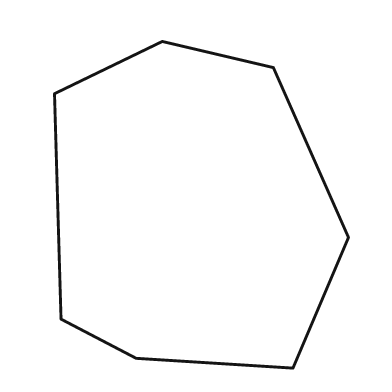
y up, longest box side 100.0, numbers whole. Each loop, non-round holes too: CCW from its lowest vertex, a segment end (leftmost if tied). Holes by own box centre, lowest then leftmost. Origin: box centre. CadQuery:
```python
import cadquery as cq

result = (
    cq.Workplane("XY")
    .moveTo(28.0, -50.0)
    .lineTo(45.0, -10.0)
    .lineTo(22.0, 42.0)
    .lineTo(-12.0, 50.0)
    .lineTo(-45.0, 34.0)
    .lineTo(-43.0, -35.0)
    .lineTo(-20.0, -47.0)
    .close()
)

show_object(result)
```